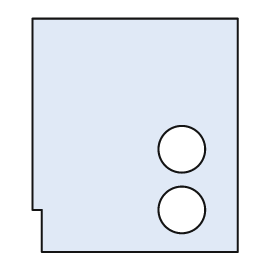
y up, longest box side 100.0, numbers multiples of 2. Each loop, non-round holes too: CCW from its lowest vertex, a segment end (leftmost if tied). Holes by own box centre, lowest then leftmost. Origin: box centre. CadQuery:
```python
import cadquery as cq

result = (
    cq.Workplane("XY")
    .moveTo(-40.0, -50.0)
    .lineTo(44.0, -50.0)
    .lineTo(44.0, 50.0)
    .lineTo(-44.0, 50.0)
    .lineTo(-44.0, -32.0)
    .lineTo(-40.0, -32.0)
    .close()
    .moveTo(20.0, -32.0)
    .circle(10.0)
    .moveTo(20.0, -6.0)
    .circle(10.0)
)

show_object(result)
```